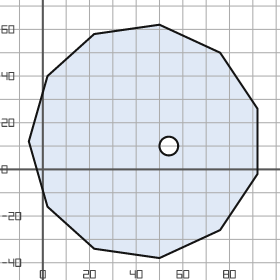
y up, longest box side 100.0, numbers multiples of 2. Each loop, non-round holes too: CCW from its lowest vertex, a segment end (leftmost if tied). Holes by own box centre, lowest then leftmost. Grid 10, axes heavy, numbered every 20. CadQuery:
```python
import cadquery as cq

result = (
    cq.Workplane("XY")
    .moveTo(50.0, -38.0)
    .lineTo(76.0, -26.0)
    .lineTo(92.0, -2.0)
    .lineTo(92.0, 26.0)
    .lineTo(76.0, 50.0)
    .lineTo(50.0, 62.0)
    .lineTo(22.0, 58.0)
    .lineTo(2.0, 40.0)
    .lineTo(-6.0, 12.0)
    .lineTo(2.0, -16.0)
    .lineTo(22.0, -34.0)
    .close()
    .moveTo(54.0, 10.0)
    .circle(4.0)
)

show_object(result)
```